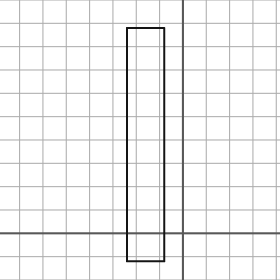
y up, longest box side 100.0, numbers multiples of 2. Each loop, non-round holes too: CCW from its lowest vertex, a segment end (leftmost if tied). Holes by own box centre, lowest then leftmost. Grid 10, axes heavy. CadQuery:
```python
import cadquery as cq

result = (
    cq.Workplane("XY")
    .moveTo(-24.0, -12.0)
    .lineTo(-8.0, -12.0)
    .lineTo(-8.0, 88.0)
    .lineTo(-24.0, 88.0)
    .close()
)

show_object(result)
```